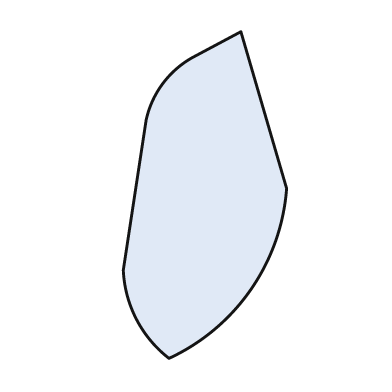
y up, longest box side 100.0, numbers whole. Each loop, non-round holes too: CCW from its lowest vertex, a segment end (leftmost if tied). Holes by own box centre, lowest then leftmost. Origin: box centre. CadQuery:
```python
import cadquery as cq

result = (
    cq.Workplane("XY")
    .moveTo(-11.0, -50.0)
    .threePointArc((14.0, -29.0), (25.0, 2.0))
    .lineTo(11.0, 50.0)
    .lineTo(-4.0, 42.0)
    .threePointArc((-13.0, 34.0), (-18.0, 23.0))
    .lineTo(-25.0, -23.0)
    .threePointArc((-21.0, -38.0), (-11.0, -50.0))
    .close()
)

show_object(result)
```